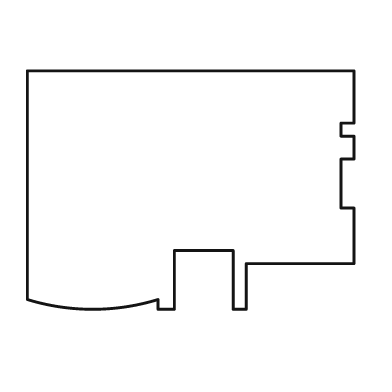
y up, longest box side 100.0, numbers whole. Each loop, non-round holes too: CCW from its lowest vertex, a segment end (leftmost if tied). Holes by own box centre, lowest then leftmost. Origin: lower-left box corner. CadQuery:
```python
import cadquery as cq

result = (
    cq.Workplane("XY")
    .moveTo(40.0, 0.0)
    .lineTo(45.0, 0.0)
    .lineTo(45.0, 18.0)
    .lineTo(63.0, 18.0)
    .lineTo(63.0, 0.0)
    .lineTo(67.0, 0.0)
    .lineTo(67.0, 14.0)
    .lineTo(100.0, 14.0)
    .lineTo(100.0, 31.0)
    .lineTo(96.0, 31.0)
    .lineTo(96.0, 46.0)
    .lineTo(100.0, 46.0)
    .lineTo(100.0, 53.0)
    .lineTo(96.0, 53.0)
    .lineTo(96.0, 57.0)
    .lineTo(100.0, 57.0)
    .lineTo(100.0, 73.0)
    .lineTo(0.0, 73.0)
    .lineTo(0.0, 3.0)
    .threePointArc((20.0, 0.0), (40.0, 3.0))
    .close()
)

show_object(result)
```